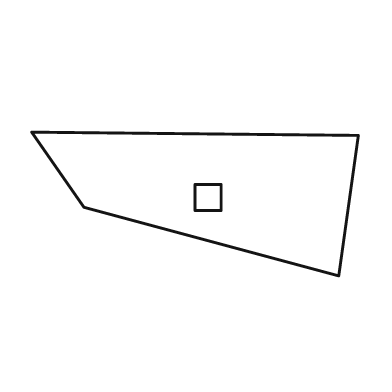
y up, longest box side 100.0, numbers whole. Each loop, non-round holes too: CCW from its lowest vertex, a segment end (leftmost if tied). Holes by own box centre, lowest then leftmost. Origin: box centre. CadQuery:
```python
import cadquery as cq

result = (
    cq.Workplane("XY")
    .moveTo(44.0, -22.0)
    .lineTo(50.0, 21.0)
    .lineTo(-50.0, 22.0)
    .lineTo(-34.0, -1.0)
    .close()
    .moveTo(0.0, -2.0)
    .lineTo(8.0, -2.0)
    .lineTo(8.0, 6.0)
    .lineTo(0.0, 6.0)
    .close()
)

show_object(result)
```